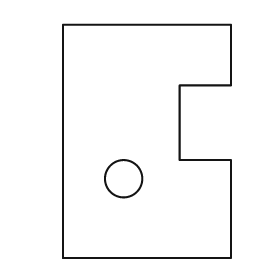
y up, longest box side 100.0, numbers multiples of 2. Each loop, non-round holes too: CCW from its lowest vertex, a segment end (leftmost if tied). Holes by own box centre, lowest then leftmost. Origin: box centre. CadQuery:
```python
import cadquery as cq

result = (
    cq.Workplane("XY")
    .moveTo(-36.0, -50.0)
    .lineTo(36.0, -50.0)
    .lineTo(36.0, -8.0)
    .lineTo(14.0, -8.0)
    .lineTo(14.0, 24.0)
    .lineTo(36.0, 24.0)
    .lineTo(36.0, 50.0)
    .lineTo(-36.0, 50.0)
    .close()
    .moveTo(-10.0, -16.0)
    .circle(8.0)
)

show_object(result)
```